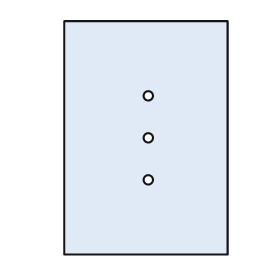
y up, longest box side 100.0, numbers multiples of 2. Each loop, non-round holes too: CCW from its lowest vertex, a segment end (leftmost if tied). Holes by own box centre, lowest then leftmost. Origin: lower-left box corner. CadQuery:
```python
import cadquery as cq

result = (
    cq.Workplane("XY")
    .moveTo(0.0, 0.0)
    .lineTo(70.0, 0.0)
    .lineTo(70.0, 100.0)
    .lineTo(0.0, 100.0)
    .close()
    .moveTo(36.0, 32.0)
    .circle(2.0)
    .moveTo(36.0, 50.0)
    .circle(2.0)
    .moveTo(36.0, 68.0)
    .circle(2.0)
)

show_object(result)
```